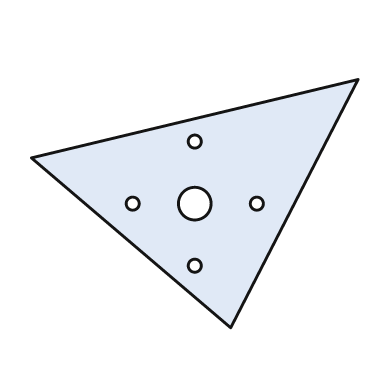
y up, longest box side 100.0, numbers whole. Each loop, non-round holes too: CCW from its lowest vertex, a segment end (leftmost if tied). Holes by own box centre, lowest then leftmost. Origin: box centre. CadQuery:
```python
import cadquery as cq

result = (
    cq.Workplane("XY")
    .moveTo(11.0, -38.0)
    .lineTo(50.0, 38.0)
    .lineTo(-50.0, 14.0)
    .close()
    .moveTo(0.0, -19.0)
    .circle(2.0)
    .moveTo(-19.0, 0.0)
    .circle(2.0)
    .moveTo(0.0, 0.0)
    .circle(5.0)
    .moveTo(19.0, 0.0)
    .circle(2.0)
    .moveTo(0.0, 19.0)
    .circle(2.0)
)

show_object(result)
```